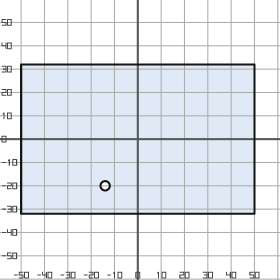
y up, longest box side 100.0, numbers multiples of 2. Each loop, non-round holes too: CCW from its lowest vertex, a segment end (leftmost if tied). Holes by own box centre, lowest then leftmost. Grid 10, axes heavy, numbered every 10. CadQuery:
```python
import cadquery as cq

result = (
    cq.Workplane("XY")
    .moveTo(-50.0, -32.0)
    .lineTo(50.0, -32.0)
    .lineTo(50.0, 32.0)
    .lineTo(-50.0, 32.0)
    .close()
    .moveTo(-14.0, -20.0)
    .circle(2.0)
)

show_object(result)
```